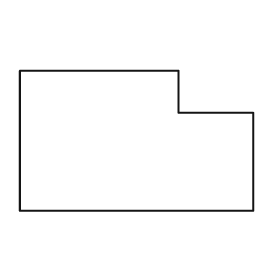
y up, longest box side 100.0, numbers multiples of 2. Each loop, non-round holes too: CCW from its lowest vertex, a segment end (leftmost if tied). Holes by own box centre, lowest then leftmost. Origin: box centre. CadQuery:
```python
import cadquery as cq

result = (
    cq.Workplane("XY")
    .moveTo(-50.0, -30.0)
    .lineTo(50.0, -30.0)
    .lineTo(50.0, 12.0)
    .lineTo(18.0, 12.0)
    .lineTo(18.0, 30.0)
    .lineTo(-50.0, 30.0)
    .close()
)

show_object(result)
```